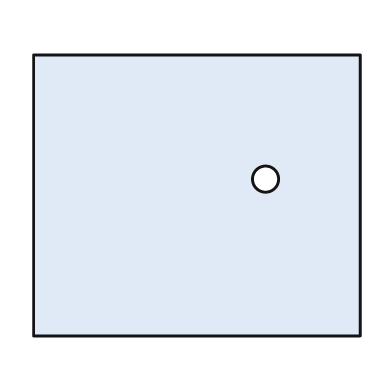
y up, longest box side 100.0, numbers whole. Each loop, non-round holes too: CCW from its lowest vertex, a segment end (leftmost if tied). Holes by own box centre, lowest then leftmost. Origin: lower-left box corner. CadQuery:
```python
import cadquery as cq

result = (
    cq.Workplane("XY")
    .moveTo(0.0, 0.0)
    .lineTo(100.0, 0.0)
    .lineTo(100.0, 86.0)
    .lineTo(0.0, 86.0)
    .close()
    .moveTo(71.0, 48.0)
    .circle(4.0)
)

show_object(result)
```